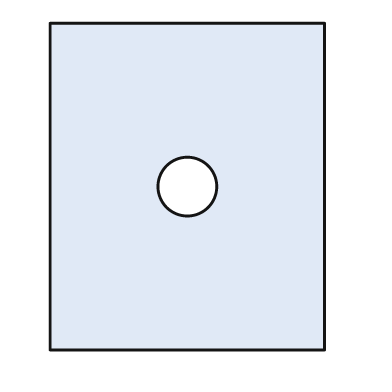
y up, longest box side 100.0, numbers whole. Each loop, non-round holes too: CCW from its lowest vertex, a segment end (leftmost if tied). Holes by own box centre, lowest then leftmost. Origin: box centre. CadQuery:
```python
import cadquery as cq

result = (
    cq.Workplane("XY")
    .moveTo(-42.0, -50.0)
    .lineTo(42.0, -50.0)
    .lineTo(42.0, 50.0)
    .lineTo(-42.0, 50.0)
    .close()
    .moveTo(0.0, 0.0)
    .circle(9.0)
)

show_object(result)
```